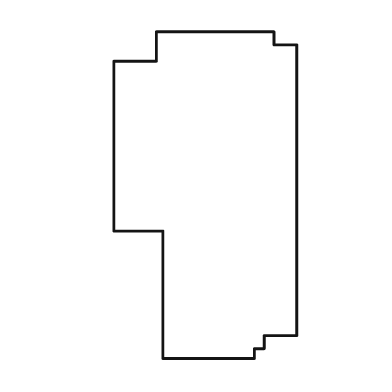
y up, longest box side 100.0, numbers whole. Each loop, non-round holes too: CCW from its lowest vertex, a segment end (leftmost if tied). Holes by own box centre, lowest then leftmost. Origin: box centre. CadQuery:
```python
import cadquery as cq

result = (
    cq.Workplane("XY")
    .moveTo(-13.0, -50.0)
    .lineTo(15.0, -50.0)
    .lineTo(15.0, -47.0)
    .lineTo(18.0, -47.0)
    .lineTo(18.0, -43.0)
    .lineTo(28.0, -43.0)
    .lineTo(28.0, 46.0)
    .lineTo(21.0, 46.0)
    .lineTo(21.0, 50.0)
    .lineTo(-15.0, 50.0)
    .lineTo(-15.0, 41.0)
    .lineTo(-28.0, 41.0)
    .lineTo(-28.0, -11.0)
    .lineTo(-13.0, -11.0)
    .close()
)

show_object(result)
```